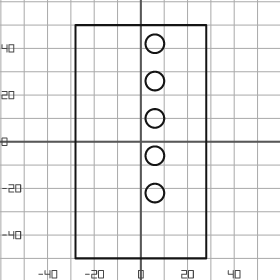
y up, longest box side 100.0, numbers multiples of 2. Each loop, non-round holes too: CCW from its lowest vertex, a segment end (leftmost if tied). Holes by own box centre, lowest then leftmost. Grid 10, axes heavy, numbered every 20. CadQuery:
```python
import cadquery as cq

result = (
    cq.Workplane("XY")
    .moveTo(-28.0, -50.0)
    .lineTo(28.0, -50.0)
    .lineTo(28.0, 50.0)
    .lineTo(-28.0, 50.0)
    .close()
    .moveTo(6.0, -22.0)
    .circle(4.0)
    .moveTo(6.0, -6.0)
    .circle(4.0)
    .moveTo(6.0, 10.0)
    .circle(4.0)
    .moveTo(6.0, 26.0)
    .circle(4.0)
    .moveTo(6.0, 42.0)
    .circle(4.0)
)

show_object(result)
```